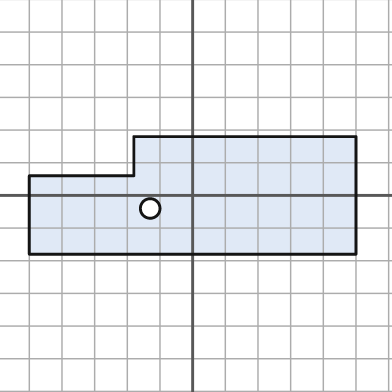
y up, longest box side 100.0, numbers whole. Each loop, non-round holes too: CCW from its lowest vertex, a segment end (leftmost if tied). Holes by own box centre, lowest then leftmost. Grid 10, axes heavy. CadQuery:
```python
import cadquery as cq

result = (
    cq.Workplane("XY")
    .moveTo(-50.0, -18.0)
    .lineTo(50.0, -18.0)
    .lineTo(50.0, 18.0)
    .lineTo(-18.0, 18.0)
    .lineTo(-18.0, 6.0)
    .lineTo(-50.0, 6.0)
    .close()
    .moveTo(-13.0, -4.0)
    .circle(3.0)
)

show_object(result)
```